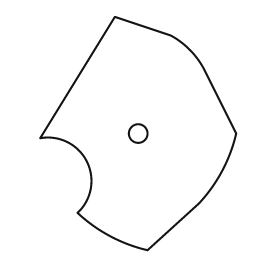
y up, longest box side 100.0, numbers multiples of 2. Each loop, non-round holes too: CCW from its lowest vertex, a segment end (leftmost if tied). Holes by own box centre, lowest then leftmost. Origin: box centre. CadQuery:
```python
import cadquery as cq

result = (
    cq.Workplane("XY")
    .moveTo(4.0, -50.0)
    .lineTo(26.0, -30.0)
    .threePointArc((36.0, -16.0), (42.0, 0.0))
    .lineTo(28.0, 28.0)
    .threePointArc((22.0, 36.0), (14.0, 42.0))
    .lineTo(-10.0, 50.0)
    .lineTo(-42.0, -2.0)
    .threePointArc((-22.0, -12.0), (-26.0, -34.0))
    .threePointArc((-12.0, -44.0), (4.0, -50.0))
    .close()
    .moveTo(0.0, 0.0)
    .circle(4.0)
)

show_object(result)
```